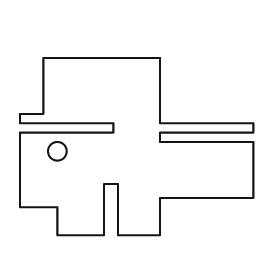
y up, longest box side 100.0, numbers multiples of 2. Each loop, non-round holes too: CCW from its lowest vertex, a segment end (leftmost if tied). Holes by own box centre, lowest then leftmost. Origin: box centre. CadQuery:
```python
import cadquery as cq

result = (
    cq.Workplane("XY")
    .moveTo(-34.0, -38.0)
    .lineTo(-14.0, -38.0)
    .lineTo(-14.0, -16.0)
    .lineTo(-8.0, -16.0)
    .lineTo(-8.0, -38.0)
    .lineTo(10.0, -38.0)
    .lineTo(10.0, -22.0)
    .lineTo(50.0, -22.0)
    .lineTo(50.0, 2.0)
    .lineTo(10.0, 2.0)
    .lineTo(10.0, 6.0)
    .lineTo(50.0, 6.0)
    .lineTo(50.0, 10.0)
    .lineTo(10.0, 10.0)
    .lineTo(10.0, 38.0)
    .lineTo(-40.0, 38.0)
    .lineTo(-40.0, 14.0)
    .lineTo(-50.0, 14.0)
    .lineTo(-50.0, 10.0)
    .lineTo(-10.0, 10.0)
    .lineTo(-10.0, 6.0)
    .lineTo(-50.0, 6.0)
    .lineTo(-50.0, -26.0)
    .lineTo(-34.0, -26.0)
    .close()
    .moveTo(-34.0, -2.0)
    .circle(4.0)
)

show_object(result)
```